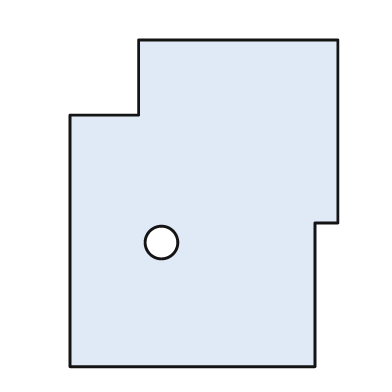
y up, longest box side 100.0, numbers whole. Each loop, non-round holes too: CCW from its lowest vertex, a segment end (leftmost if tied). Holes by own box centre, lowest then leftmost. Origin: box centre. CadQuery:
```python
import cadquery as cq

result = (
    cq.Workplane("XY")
    .moveTo(-41.0, -50.0)
    .lineTo(34.0, -50.0)
    .lineTo(34.0, -6.0)
    .lineTo(41.0, -6.0)
    .lineTo(41.0, 50.0)
    .lineTo(-20.0, 50.0)
    .lineTo(-20.0, 27.0)
    .lineTo(-41.0, 27.0)
    .close()
    .moveTo(-13.0, -12.0)
    .circle(5.0)
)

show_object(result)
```